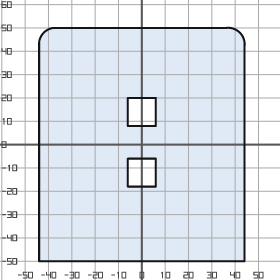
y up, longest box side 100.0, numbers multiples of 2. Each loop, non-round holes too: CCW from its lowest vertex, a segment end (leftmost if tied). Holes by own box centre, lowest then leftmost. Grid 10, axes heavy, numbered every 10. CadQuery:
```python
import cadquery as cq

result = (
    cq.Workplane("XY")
    .moveTo(-44.0, -50.0)
    .lineTo(44.0, -50.0)
    .lineTo(44.0, 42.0)
    .threePointArc((42.0, 48.0), (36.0, 50.0))
    .lineTo(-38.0, 50.0)
    .threePointArc((-42.0, 48.0), (-44.0, 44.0))
    .close()
    .moveTo(-6.0, -18.0)
    .lineTo(6.0, -18.0)
    .lineTo(6.0, -6.0)
    .lineTo(-6.0, -6.0)
    .close()
    .moveTo(-6.0, 8.0)
    .lineTo(6.0, 8.0)
    .lineTo(6.0, 20.0)
    .lineTo(-6.0, 20.0)
    .close()
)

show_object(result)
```